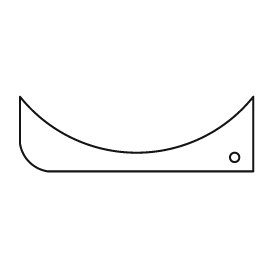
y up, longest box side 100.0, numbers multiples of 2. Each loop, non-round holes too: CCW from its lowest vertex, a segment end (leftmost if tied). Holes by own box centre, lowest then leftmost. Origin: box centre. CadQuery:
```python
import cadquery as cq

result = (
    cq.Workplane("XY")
    .moveTo(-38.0, -16.0)
    .lineTo(50.0, -16.0)
    .lineTo(50.0, 16.0)
    .threePointArc((0.0, -8.0), (-50.0, 16.0))
    .lineTo(-50.0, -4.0)
    .threePointArc((-46.0, -12.0), (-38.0, -16.0))
    .close()
    .moveTo(42.0, -10.0)
    .circle(2.0)
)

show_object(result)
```